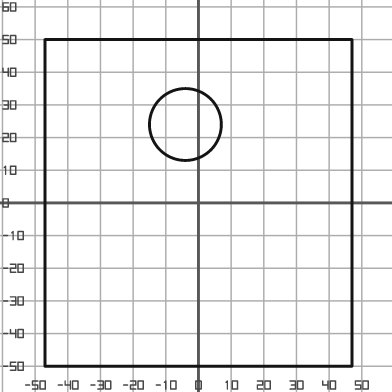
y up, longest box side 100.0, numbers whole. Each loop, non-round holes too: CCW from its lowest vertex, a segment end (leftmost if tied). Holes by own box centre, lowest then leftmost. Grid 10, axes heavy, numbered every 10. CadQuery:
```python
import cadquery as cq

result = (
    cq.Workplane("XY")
    .moveTo(-47.0, -50.0)
    .lineTo(47.0, -50.0)
    .lineTo(47.0, 50.0)
    .lineTo(-47.0, 50.0)
    .close()
    .moveTo(-4.0, 24.0)
    .circle(11.0)
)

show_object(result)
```